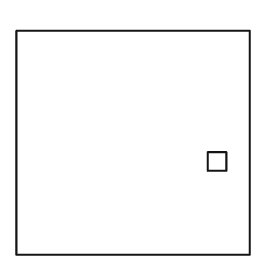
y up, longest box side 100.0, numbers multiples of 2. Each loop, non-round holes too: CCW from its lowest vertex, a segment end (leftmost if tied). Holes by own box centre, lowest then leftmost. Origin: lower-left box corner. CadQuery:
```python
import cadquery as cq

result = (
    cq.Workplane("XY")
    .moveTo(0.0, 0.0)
    .lineTo(100.0, 0.0)
    .lineTo(100.0, 96.0)
    .lineTo(0.0, 96.0)
    .close()
    .moveTo(82.0, 36.0)
    .lineTo(90.0, 36.0)
    .lineTo(90.0, 44.0)
    .lineTo(82.0, 44.0)
    .close()
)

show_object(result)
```